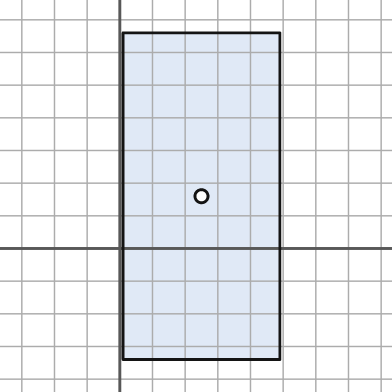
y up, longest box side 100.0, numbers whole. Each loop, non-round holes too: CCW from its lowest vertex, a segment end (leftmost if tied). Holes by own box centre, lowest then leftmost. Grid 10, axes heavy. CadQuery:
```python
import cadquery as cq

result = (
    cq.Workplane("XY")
    .moveTo(1.0, -34.0)
    .lineTo(49.0, -34.0)
    .lineTo(49.0, 66.0)
    .lineTo(1.0, 66.0)
    .close()
    .moveTo(25.0, 16.0)
    .circle(2.0)
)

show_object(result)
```